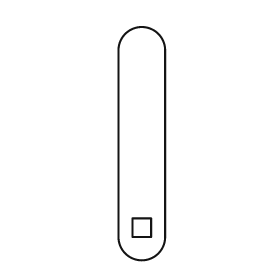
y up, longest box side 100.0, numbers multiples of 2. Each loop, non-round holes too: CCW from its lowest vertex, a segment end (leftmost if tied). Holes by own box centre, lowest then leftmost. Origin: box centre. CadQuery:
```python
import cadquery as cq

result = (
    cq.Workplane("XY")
    .moveTo(-10.0, -40.0)
    .threePointArc((0.0, -50.0), (10.0, -40.0))
    .lineTo(10.0, 40.0)
    .threePointArc((0.0, 50.0), (-10.0, 40.0))
    .close()
    .moveTo(-4.0, -40.0)
    .lineTo(4.0, -40.0)
    .lineTo(4.0, -32.0)
    .lineTo(-4.0, -32.0)
    .close()
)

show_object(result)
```